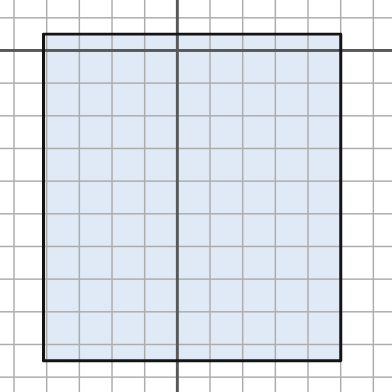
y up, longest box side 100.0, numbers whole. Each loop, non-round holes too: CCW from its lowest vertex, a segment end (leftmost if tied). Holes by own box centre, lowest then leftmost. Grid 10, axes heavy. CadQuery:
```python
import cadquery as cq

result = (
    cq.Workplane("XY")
    .moveTo(-41.0, -95.0)
    .lineTo(50.0, -95.0)
    .lineTo(50.0, 5.0)
    .lineTo(-41.0, 5.0)
    .close()
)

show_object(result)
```